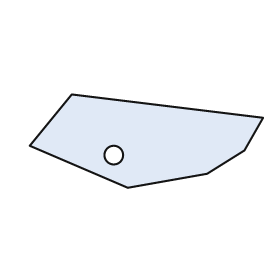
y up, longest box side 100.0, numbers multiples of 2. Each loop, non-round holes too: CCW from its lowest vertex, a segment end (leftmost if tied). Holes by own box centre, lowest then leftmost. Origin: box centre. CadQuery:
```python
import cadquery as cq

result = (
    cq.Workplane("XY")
    .moveTo(-8.0, -20.0)
    .lineTo(26.0, -14.0)
    .lineTo(42.0, -4.0)
    .lineTo(50.0, 10.0)
    .lineTo(-32.0, 20.0)
    .lineTo(-50.0, -2.0)
    .close()
    .moveTo(-14.0, -6.0)
    .circle(4.0)
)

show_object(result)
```